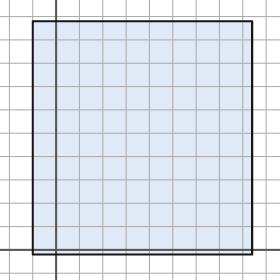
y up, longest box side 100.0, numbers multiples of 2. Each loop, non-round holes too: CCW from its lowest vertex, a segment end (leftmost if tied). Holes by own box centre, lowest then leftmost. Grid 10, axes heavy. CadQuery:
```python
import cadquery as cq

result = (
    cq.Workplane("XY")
    .moveTo(-10.0, -2.0)
    .lineTo(84.0, -2.0)
    .lineTo(84.0, 98.0)
    .lineTo(-10.0, 98.0)
    .close()
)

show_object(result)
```